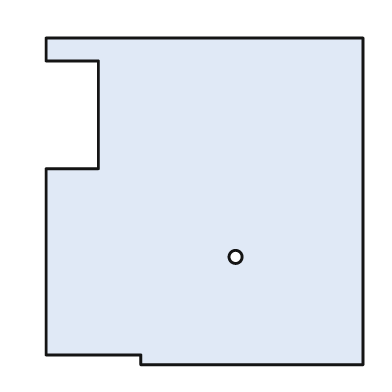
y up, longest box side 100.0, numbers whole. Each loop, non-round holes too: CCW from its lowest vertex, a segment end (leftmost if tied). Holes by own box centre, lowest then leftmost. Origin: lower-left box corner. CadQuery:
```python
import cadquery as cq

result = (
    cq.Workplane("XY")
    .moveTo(29.0, 0.0)
    .lineTo(97.0, 0.0)
    .lineTo(97.0, 100.0)
    .lineTo(0.0, 100.0)
    .lineTo(0.0, 93.0)
    .lineTo(16.0, 93.0)
    .lineTo(16.0, 60.0)
    .lineTo(0.0, 60.0)
    .lineTo(0.0, 3.0)
    .lineTo(29.0, 3.0)
    .close()
    .moveTo(58.0, 33.0)
    .circle(2.0)
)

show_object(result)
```